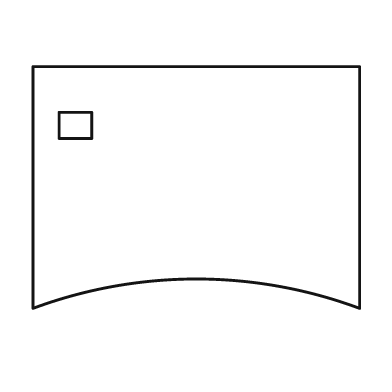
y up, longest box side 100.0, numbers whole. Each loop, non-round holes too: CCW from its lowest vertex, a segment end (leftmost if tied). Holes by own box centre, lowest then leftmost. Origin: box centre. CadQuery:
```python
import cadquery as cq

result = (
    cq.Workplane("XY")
    .moveTo(-50.0, -37.0)
    .threePointArc((0.0, -28.0), (50.0, -37.0))
    .lineTo(50.0, 37.0)
    .lineTo(-50.0, 37.0)
    .close()
    .moveTo(-42.0, 15.0)
    .lineTo(-32.0, 15.0)
    .lineTo(-32.0, 23.0)
    .lineTo(-42.0, 23.0)
    .close()
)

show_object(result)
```